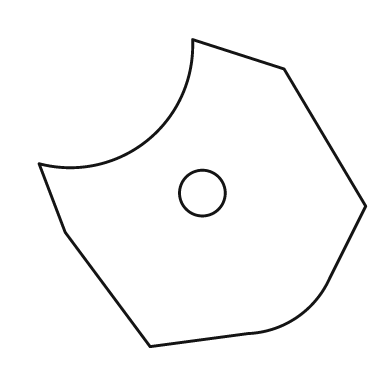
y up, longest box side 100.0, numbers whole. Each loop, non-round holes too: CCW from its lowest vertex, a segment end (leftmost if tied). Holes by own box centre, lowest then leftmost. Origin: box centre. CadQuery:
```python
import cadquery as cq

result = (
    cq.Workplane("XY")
    .moveTo(-16.0, -47.0)
    .lineTo(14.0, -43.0)
    .threePointArc((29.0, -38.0), (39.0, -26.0))
    .lineTo(50.0, -4.0)
    .lineTo(25.0, 38.0)
    .lineTo(-3.0, 47.0)
    .threePointArc((-17.0, 16.0), (-50.0, 9.0))
    .lineTo(-42.0, -12.0)
    .close()
    .moveTo(0.0, 0.0)
    .circle(7.0)
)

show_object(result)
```